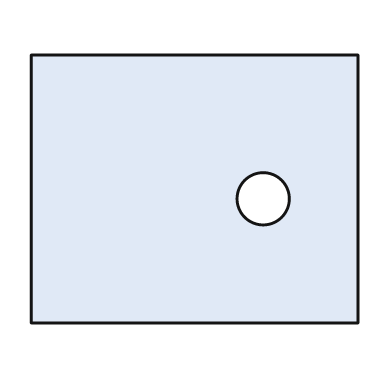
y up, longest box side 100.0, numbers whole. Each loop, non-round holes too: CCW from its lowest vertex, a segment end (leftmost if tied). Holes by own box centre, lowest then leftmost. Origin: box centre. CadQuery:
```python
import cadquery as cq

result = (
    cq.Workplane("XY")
    .moveTo(-50.0, -41.0)
    .lineTo(50.0, -41.0)
    .lineTo(50.0, 41.0)
    .lineTo(-50.0, 41.0)
    .close()
    .moveTo(21.0, -3.0)
    .circle(8.0)
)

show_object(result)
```